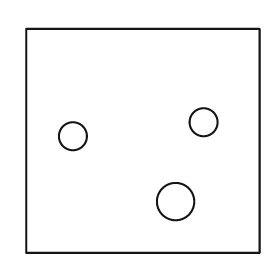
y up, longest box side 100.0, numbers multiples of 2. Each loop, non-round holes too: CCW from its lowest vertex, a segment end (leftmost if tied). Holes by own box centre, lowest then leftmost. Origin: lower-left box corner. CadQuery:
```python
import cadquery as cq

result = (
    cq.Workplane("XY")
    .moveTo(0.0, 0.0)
    .lineTo(100.0, 0.0)
    .lineTo(100.0, 96.0)
    .lineTo(0.0, 96.0)
    .close()
    .moveTo(64.0, 22.0)
    .circle(8.0)
    .moveTo(20.0, 50.0)
    .circle(6.0)
    .moveTo(76.0, 56.0)
    .circle(6.0)
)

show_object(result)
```